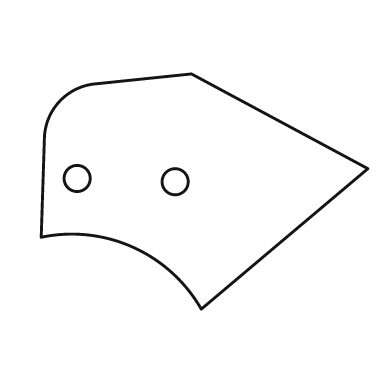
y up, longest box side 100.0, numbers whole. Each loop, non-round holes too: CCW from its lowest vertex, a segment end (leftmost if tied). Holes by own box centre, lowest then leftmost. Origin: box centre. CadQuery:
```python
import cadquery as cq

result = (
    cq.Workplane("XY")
    .moveTo(-1.0, -36.0)
    .lineTo(50.0, 7.0)
    .lineTo(-4.0, 36.0)
    .lineTo(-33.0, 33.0)
    .threePointArc((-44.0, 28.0), (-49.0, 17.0))
    .lineTo(-50.0, -14.0)
    .threePointArc((-22.0, -17.0), (-1.0, -36.0))
    .close()
    .moveTo(-9.0, 3.0)
    .circle(4.0)
    .moveTo(-39.0, 4.0)
    .circle(4.0)
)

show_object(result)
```